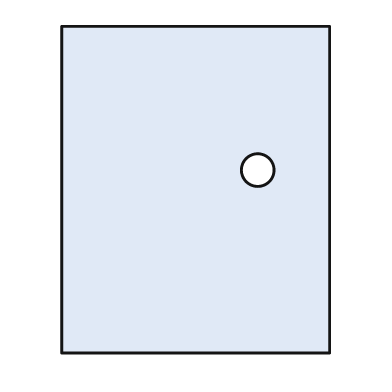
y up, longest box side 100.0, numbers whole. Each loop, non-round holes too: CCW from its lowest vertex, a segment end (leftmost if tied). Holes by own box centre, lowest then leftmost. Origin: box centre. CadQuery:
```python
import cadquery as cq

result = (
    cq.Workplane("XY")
    .moveTo(-41.0, -50.0)
    .lineTo(41.0, -50.0)
    .lineTo(41.0, 50.0)
    .lineTo(-41.0, 50.0)
    .close()
    .moveTo(19.0, 6.0)
    .circle(5.0)
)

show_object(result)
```